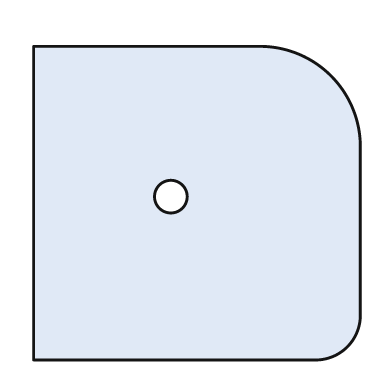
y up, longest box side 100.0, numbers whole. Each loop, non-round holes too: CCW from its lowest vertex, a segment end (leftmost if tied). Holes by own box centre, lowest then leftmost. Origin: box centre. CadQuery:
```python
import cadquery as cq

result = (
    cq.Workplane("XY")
    .moveTo(-50.0, -48.0)
    .lineTo(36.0, -48.0)
    .threePointArc((46.0, -44.0), (50.0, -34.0))
    .lineTo(50.0, 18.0)
    .threePointArc((41.0, 39.0), (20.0, 48.0))
    .lineTo(-50.0, 48.0)
    .close()
    .moveTo(-8.0, 2.0)
    .circle(5.0)
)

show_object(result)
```